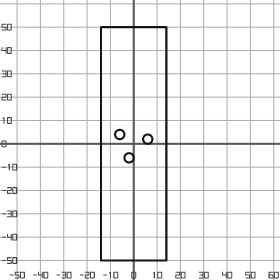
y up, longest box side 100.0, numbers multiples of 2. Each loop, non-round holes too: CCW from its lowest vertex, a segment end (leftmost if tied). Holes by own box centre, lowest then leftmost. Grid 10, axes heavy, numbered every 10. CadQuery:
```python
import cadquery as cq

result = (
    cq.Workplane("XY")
    .moveTo(-14.0, -50.0)
    .lineTo(14.0, -50.0)
    .lineTo(14.0, 50.0)
    .lineTo(-14.0, 50.0)
    .close()
    .moveTo(-2.0, -6.0)
    .circle(2.0)
    .moveTo(6.0, 2.0)
    .circle(2.0)
    .moveTo(-6.0, 4.0)
    .circle(2.0)
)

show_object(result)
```